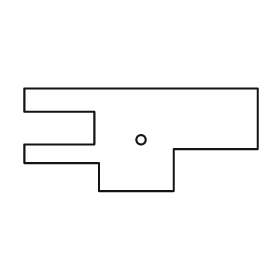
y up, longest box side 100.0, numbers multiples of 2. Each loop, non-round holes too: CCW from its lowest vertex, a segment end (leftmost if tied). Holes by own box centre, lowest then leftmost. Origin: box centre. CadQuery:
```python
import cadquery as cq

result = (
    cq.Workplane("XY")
    .moveTo(-18.0, -22.0)
    .lineTo(14.0, -22.0)
    .lineTo(14.0, -4.0)
    .lineTo(50.0, -4.0)
    .lineTo(50.0, 22.0)
    .lineTo(-50.0, 22.0)
    .lineTo(-50.0, 12.0)
    .lineTo(-20.0, 12.0)
    .lineTo(-20.0, -2.0)
    .lineTo(-50.0, -2.0)
    .lineTo(-50.0, -10.0)
    .lineTo(-18.0, -10.0)
    .close()
    .moveTo(0.0, 0.0)
    .circle(2.0)
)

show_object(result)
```